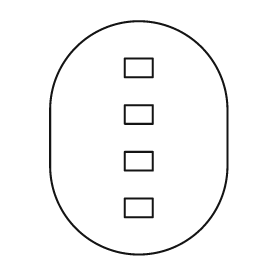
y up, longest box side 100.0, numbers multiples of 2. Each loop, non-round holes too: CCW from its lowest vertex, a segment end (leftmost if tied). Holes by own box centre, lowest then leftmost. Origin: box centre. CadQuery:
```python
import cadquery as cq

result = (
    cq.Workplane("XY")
    .moveTo(-38.0, -12.0)
    .threePointArc((0.0, -50.0), (38.0, -12.0))
    .lineTo(38.0, 12.0)
    .threePointArc((0.0, 50.0), (-38.0, 12.0))
    .close()
    .moveTo(-6.0, -34.0)
    .lineTo(6.0, -34.0)
    .lineTo(6.0, -26.0)
    .lineTo(-6.0, -26.0)
    .close()
    .moveTo(-6.0, -14.0)
    .lineTo(6.0, -14.0)
    .lineTo(6.0, -6.0)
    .lineTo(-6.0, -6.0)
    .close()
    .moveTo(-6.0, 6.0)
    .lineTo(6.0, 6.0)
    .lineTo(6.0, 14.0)
    .lineTo(-6.0, 14.0)
    .close()
    .moveTo(-6.0, 26.0)
    .lineTo(6.0, 26.0)
    .lineTo(6.0, 34.0)
    .lineTo(-6.0, 34.0)
    .close()
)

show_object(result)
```